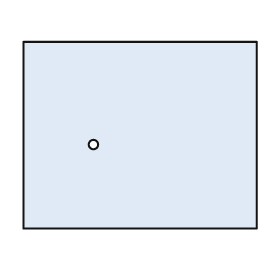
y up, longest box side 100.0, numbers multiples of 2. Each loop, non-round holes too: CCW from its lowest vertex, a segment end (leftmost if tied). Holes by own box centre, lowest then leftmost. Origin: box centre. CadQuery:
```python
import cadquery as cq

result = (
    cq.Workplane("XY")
    .moveTo(-50.0, -40.0)
    .lineTo(50.0, -40.0)
    .lineTo(50.0, 40.0)
    .lineTo(-50.0, 40.0)
    .close()
    .moveTo(-20.0, -4.0)
    .circle(2.0)
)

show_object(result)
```